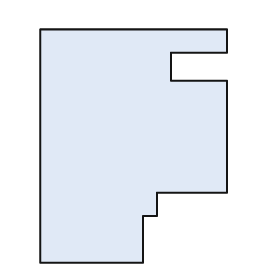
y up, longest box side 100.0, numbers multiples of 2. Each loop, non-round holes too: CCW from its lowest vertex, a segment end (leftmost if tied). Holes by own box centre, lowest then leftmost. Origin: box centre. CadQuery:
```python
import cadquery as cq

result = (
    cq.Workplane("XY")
    .moveTo(-40.0, -50.0)
    .lineTo(4.0, -50.0)
    .lineTo(4.0, -30.0)
    .lineTo(10.0, -30.0)
    .lineTo(10.0, -20.0)
    .lineTo(40.0, -20.0)
    .lineTo(40.0, 28.0)
    .lineTo(16.0, 28.0)
    .lineTo(16.0, 40.0)
    .lineTo(40.0, 40.0)
    .lineTo(40.0, 50.0)
    .lineTo(-40.0, 50.0)
    .close()
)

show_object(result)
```